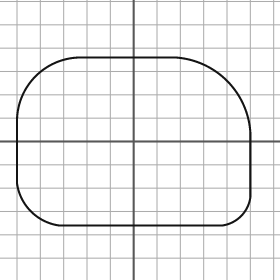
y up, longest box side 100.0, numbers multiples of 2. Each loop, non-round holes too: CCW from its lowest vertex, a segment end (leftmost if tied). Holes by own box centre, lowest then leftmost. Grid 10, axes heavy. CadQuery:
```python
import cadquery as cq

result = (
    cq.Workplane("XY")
    .moveTo(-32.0, -36.0)
    .lineTo(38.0, -36.0)
    .threePointArc((46.0, -32.0), (50.0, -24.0))
    .lineTo(50.0, 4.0)
    .threePointArc((40.0, 26.0), (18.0, 36.0))
    .lineTo(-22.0, 36.0)
    .threePointArc((-42.0, 28.0), (-50.0, 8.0))
    .lineTo(-50.0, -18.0)
    .threePointArc((-44.0, -30.0), (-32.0, -36.0))
    .close()
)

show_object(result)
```